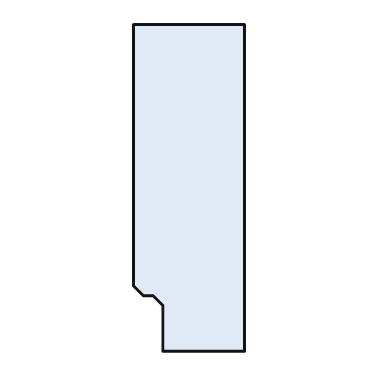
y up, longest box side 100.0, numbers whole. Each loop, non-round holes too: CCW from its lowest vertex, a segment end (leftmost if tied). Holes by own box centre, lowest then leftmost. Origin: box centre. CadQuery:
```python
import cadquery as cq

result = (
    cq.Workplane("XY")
    .moveTo(-8.0, -50.0)
    .lineTo(17.0, -50.0)
    .lineTo(17.0, 50.0)
    .lineTo(-17.0, 50.0)
    .lineTo(-17.0, -30.0)
    .lineTo(-14.0, -33.0)
    .lineTo(-11.0, -33.0)
    .lineTo(-8.0, -36.0)
    .close()
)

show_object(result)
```